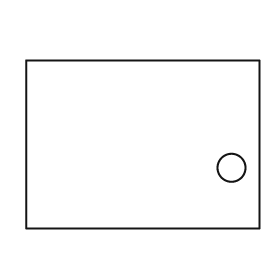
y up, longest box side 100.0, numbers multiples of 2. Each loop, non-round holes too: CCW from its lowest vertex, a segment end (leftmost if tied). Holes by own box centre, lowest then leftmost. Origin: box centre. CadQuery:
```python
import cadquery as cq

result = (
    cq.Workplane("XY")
    .moveTo(-50.0, -36.0)
    .lineTo(50.0, -36.0)
    .lineTo(50.0, 36.0)
    .lineTo(-50.0, 36.0)
    .close()
    .moveTo(38.0, -10.0)
    .circle(6.0)
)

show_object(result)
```